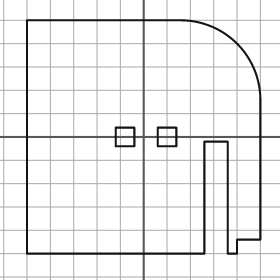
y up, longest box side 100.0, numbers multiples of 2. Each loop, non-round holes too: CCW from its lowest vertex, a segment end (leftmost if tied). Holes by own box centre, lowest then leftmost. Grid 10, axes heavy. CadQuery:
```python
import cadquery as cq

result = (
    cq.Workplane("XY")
    .moveTo(-50.0, -50.0)
    .lineTo(26.0, -50.0)
    .lineTo(26.0, -2.0)
    .lineTo(36.0, -2.0)
    .lineTo(36.0, -50.0)
    .lineTo(40.0, -50.0)
    .lineTo(40.0, -44.0)
    .lineTo(50.0, -44.0)
    .lineTo(50.0, 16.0)
    .threePointArc((40.0, 40.0), (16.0, 50.0))
    .lineTo(-50.0, 50.0)
    .close()
    .moveTo(-12.0, -4.0)
    .lineTo(-4.0, -4.0)
    .lineTo(-4.0, 4.0)
    .lineTo(-12.0, 4.0)
    .close()
    .moveTo(6.0, -4.0)
    .lineTo(14.0, -4.0)
    .lineTo(14.0, 4.0)
    .lineTo(6.0, 4.0)
    .close()
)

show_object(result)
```